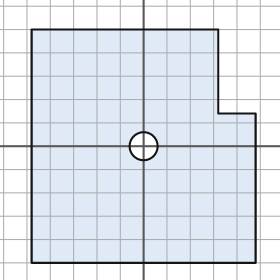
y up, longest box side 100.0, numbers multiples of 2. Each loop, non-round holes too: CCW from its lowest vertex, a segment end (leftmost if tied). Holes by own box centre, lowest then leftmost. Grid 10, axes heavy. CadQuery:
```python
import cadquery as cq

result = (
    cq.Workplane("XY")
    .moveTo(-48.0, -50.0)
    .lineTo(48.0, -50.0)
    .lineTo(48.0, 14.0)
    .lineTo(32.0, 14.0)
    .lineTo(32.0, 50.0)
    .lineTo(-48.0, 50.0)
    .close()
    .moveTo(0.0, 0.0)
    .circle(6.0)
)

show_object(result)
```